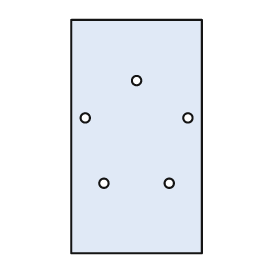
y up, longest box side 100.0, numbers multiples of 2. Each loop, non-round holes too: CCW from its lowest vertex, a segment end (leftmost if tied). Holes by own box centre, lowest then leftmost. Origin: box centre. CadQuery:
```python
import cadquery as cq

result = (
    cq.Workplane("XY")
    .moveTo(-28.0, -50.0)
    .lineTo(28.0, -50.0)
    .lineTo(28.0, 50.0)
    .lineTo(-28.0, 50.0)
    .close()
    .moveTo(-14.0, -20.0)
    .circle(2.0)
    .moveTo(14.0, -20.0)
    .circle(2.0)
    .moveTo(-22.0, 8.0)
    .circle(2.0)
    .moveTo(22.0, 8.0)
    .circle(2.0)
    .moveTo(0.0, 24.0)
    .circle(2.0)
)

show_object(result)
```